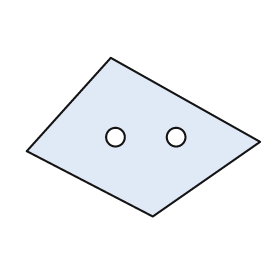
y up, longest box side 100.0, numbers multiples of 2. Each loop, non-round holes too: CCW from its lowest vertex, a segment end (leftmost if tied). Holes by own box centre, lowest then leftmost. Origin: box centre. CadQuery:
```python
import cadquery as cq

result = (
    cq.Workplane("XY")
    .moveTo(4.0, -34.0)
    .lineTo(50.0, -2.0)
    .lineTo(-14.0, 34.0)
    .lineTo(-50.0, -6.0)
    .close()
    .moveTo(-12.0, 0.0)
    .circle(4.0)
    .moveTo(14.0, 0.0)
    .circle(4.0)
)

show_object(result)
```